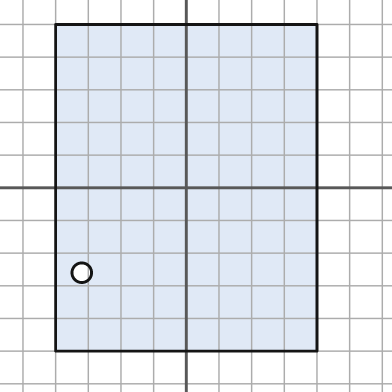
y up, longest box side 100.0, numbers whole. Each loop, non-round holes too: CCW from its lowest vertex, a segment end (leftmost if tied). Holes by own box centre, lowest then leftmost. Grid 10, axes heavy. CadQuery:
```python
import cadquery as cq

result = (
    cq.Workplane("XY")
    .moveTo(-40.0, -50.0)
    .lineTo(40.0, -50.0)
    .lineTo(40.0, 50.0)
    .lineTo(-40.0, 50.0)
    .close()
    .moveTo(-32.0, -26.0)
    .circle(3.0)
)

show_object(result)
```